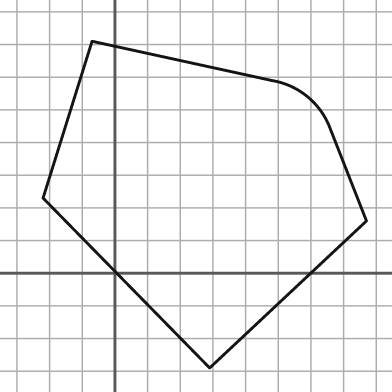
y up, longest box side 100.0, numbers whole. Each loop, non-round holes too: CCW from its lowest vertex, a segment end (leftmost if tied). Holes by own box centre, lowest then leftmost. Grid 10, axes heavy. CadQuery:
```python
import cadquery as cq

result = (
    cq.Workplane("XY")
    .moveTo(29.0, -29.0)
    .lineTo(77.0, 16.0)
    .lineTo(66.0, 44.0)
    .threePointArc((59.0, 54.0), (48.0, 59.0))
    .lineTo(-7.0, 71.0)
    .lineTo(-22.0, 23.0)
    .close()
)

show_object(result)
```